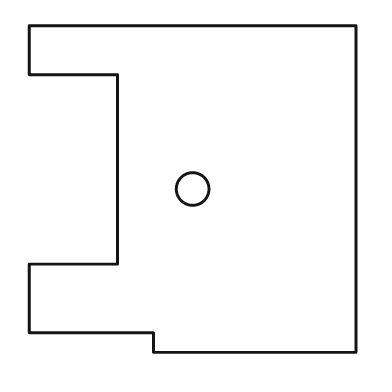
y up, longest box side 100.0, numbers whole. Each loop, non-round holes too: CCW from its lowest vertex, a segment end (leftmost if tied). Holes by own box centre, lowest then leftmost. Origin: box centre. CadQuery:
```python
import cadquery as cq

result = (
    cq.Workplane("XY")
    .moveTo(-12.0, -50.0)
    .lineTo(50.0, -50.0)
    .lineTo(50.0, 50.0)
    .lineTo(-50.0, 50.0)
    .lineTo(-50.0, 35.0)
    .lineTo(-23.0, 35.0)
    .lineTo(-23.0, -23.0)
    .lineTo(-50.0, -23.0)
    .lineTo(-50.0, -44.0)
    .lineTo(-12.0, -44.0)
    .close()
    .moveTo(0.0, 0.0)
    .circle(5.0)
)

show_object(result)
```